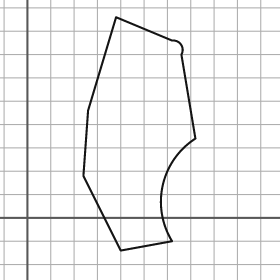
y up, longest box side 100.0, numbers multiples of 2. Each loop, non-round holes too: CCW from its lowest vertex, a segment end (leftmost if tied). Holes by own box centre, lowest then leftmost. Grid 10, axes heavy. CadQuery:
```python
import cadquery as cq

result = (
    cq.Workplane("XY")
    .moveTo(40.0, -14.0)
    .lineTo(62.0, -10.0)
    .threePointArc((58.0, 14.0), (72.0, 34.0))
    .lineTo(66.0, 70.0)
    .threePointArc((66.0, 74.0), (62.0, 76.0))
    .lineTo(38.0, 86.0)
    .lineTo(26.0, 46.0)
    .lineTo(24.0, 18.0)
    .close()
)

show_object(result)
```